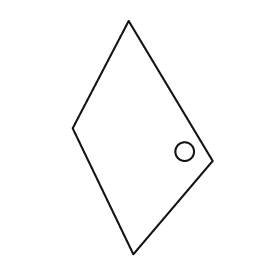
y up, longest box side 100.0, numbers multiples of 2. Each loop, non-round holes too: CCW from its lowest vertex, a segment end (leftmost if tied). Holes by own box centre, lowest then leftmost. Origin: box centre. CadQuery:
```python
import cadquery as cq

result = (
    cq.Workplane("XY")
    .moveTo(-4.0, -50.0)
    .lineTo(30.0, -10.0)
    .lineTo(-6.0, 50.0)
    .lineTo(-30.0, 4.0)
    .close()
    .moveTo(18.0, -6.0)
    .circle(4.0)
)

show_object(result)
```